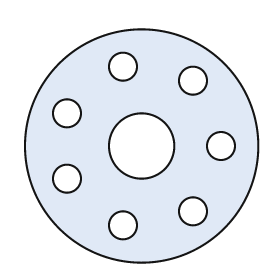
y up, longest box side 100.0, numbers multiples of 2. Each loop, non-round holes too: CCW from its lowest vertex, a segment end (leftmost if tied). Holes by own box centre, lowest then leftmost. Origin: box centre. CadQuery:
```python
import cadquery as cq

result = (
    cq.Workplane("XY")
    .moveTo(0.0, 0.0)
    .circle(50.0)
    .moveTo(-8.0, -34.0)
    .circle(6.0)
    .moveTo(22.0, -28.0)
    .circle(6.0)
    .moveTo(-32.0, -14.0)
    .circle(6.0)
    .moveTo(0.0, 0.0)
    .circle(14.0)
    .moveTo(34.0, 0.0)
    .circle(6.0)
    .moveTo(-32.0, 14.0)
    .circle(6.0)
    .moveTo(22.0, 28.0)
    .circle(6.0)
    .moveTo(-8.0, 34.0)
    .circle(6.0)
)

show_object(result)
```